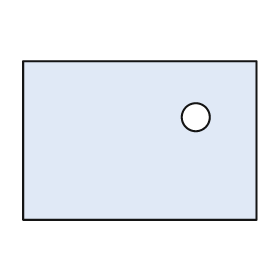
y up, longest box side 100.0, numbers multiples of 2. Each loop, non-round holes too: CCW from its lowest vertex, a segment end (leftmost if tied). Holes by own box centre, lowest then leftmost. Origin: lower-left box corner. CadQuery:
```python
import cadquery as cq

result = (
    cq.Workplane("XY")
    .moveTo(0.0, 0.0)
    .lineTo(100.0, 0.0)
    .lineTo(100.0, 68.0)
    .lineTo(0.0, 68.0)
    .close()
    .moveTo(74.0, 44.0)
    .circle(6.0)
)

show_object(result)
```